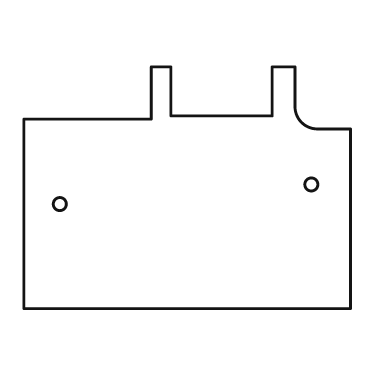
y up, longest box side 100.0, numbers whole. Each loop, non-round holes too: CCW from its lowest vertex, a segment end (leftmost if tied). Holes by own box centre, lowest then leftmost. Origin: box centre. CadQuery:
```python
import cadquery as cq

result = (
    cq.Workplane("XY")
    .moveTo(-50.0, -37.0)
    .lineTo(50.0, -37.0)
    .lineTo(50.0, 18.0)
    .lineTo(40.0, 18.0)
    .threePointArc((35.0, 20.0), (33.0, 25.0))
    .lineTo(33.0, 37.0)
    .lineTo(26.0, 37.0)
    .lineTo(26.0, 22.0)
    .lineTo(-5.0, 22.0)
    .lineTo(-5.0, 37.0)
    .lineTo(-11.0, 37.0)
    .lineTo(-11.0, 21.0)
    .lineTo(-50.0, 21.0)
    .close()
    .moveTo(-39.0, -5.0)
    .circle(2.0)
    .moveTo(38.0, 1.0)
    .circle(2.0)
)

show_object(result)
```